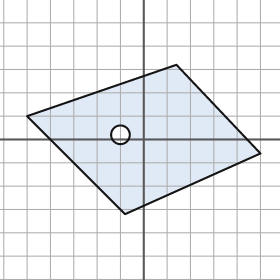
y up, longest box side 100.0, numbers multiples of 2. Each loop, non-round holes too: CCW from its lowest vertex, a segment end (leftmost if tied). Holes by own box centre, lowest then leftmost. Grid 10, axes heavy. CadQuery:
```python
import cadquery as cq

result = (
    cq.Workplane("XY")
    .moveTo(-8.0, -32.0)
    .lineTo(50.0, -6.0)
    .lineTo(14.0, 32.0)
    .lineTo(-50.0, 10.0)
    .close()
    .moveTo(-10.0, 2.0)
    .circle(4.0)
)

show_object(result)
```